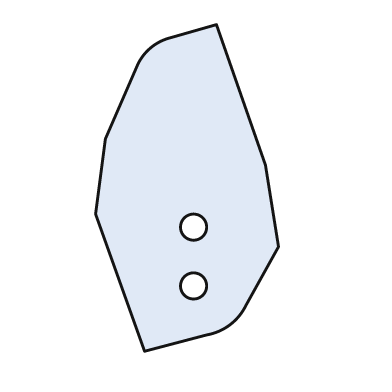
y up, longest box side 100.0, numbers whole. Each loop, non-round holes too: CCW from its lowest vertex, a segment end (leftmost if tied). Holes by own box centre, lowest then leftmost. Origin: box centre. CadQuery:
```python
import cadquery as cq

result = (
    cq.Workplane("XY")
    .moveTo(-13.0, -50.0)
    .lineTo(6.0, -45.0)
    .threePointArc((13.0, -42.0), (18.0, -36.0))
    .lineTo(28.0, -18.0)
    .lineTo(24.0, 7.0)
    .lineTo(9.0, 50.0)
    .lineTo(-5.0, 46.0)
    .threePointArc((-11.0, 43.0), (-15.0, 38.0))
    .lineTo(-25.0, 15.0)
    .lineTo(-28.0, -8.0)
    .close()
    .moveTo(2.0, -30.0)
    .circle(4.0)
    .moveTo(2.0, -12.0)
    .circle(4.0)
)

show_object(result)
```